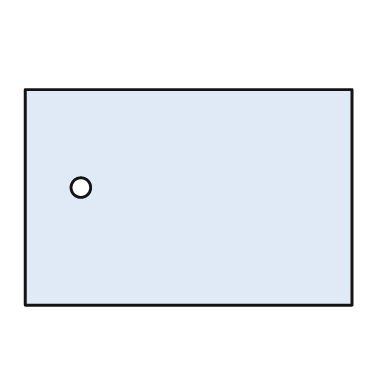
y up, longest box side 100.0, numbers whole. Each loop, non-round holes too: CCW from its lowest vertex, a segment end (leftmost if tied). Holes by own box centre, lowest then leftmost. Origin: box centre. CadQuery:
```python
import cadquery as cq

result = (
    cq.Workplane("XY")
    .moveTo(-50.0, -33.0)
    .lineTo(50.0, -33.0)
    .lineTo(50.0, 33.0)
    .lineTo(-50.0, 33.0)
    .close()
    .moveTo(-33.0, 3.0)
    .circle(3.0)
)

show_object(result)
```